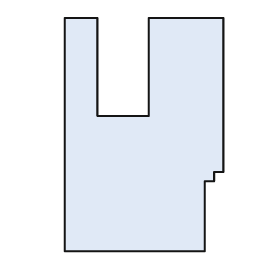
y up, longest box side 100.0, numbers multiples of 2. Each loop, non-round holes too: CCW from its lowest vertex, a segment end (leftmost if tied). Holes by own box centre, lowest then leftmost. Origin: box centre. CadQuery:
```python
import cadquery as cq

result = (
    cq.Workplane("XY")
    .moveTo(-34.0, -50.0)
    .lineTo(26.0, -50.0)
    .lineTo(26.0, -20.0)
    .lineTo(30.0, -20.0)
    .lineTo(30.0, -16.0)
    .lineTo(34.0, -16.0)
    .lineTo(34.0, 50.0)
    .lineTo(2.0, 50.0)
    .lineTo(2.0, 8.0)
    .lineTo(-20.0, 8.0)
    .lineTo(-20.0, 50.0)
    .lineTo(-34.0, 50.0)
    .close()
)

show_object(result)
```